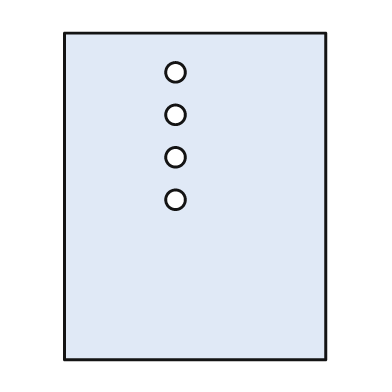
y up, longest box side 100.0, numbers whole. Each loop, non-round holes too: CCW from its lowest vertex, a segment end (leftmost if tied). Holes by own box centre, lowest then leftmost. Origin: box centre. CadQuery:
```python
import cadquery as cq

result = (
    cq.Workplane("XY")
    .moveTo(-40.0, -50.0)
    .lineTo(40.0, -50.0)
    .lineTo(40.0, 50.0)
    .lineTo(-40.0, 50.0)
    .close()
    .moveTo(-6.0, -1.0)
    .circle(3.0)
    .moveTo(-6.0, 12.0)
    .circle(3.0)
    .moveTo(-6.0, 25.0)
    .circle(3.0)
    .moveTo(-6.0, 38.0)
    .circle(3.0)
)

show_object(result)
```